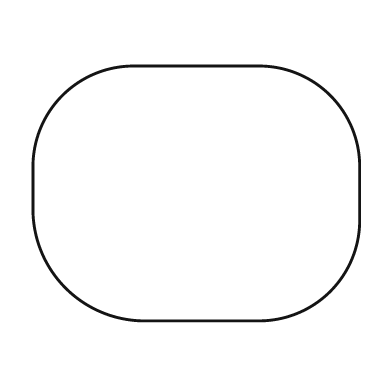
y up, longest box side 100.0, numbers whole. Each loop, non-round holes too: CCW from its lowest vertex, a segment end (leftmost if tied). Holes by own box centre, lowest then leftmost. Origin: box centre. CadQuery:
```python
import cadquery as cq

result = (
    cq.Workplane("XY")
    .moveTo(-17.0, -39.0)
    .lineTo(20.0, -39.0)
    .threePointArc((41.0, -30.0), (50.0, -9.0))
    .lineTo(50.0, 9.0)
    .threePointArc((41.0, 30.0), (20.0, 39.0))
    .lineTo(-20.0, 39.0)
    .threePointArc((-41.0, 30.0), (-50.0, 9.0))
    .lineTo(-50.0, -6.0)
    .threePointArc((-40.0, -29.0), (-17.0, -39.0))
    .close()
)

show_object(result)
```